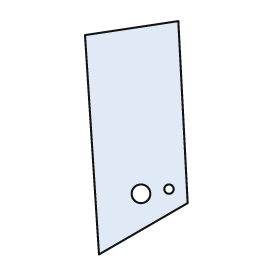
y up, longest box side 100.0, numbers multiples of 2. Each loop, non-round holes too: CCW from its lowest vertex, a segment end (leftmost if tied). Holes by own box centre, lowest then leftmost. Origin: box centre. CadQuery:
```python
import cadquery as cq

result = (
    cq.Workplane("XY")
    .moveTo(-16.0, -50.0)
    .lineTo(22.0, -28.0)
    .lineTo(18.0, 50.0)
    .lineTo(-22.0, 44.0)
    .close()
    .moveTo(2.0, -24.0)
    .circle(4.0)
    .moveTo(14.0, -22.0)
    .circle(2.0)
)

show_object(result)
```